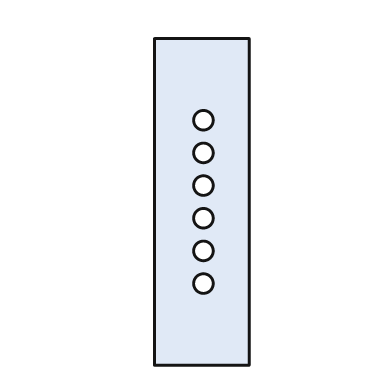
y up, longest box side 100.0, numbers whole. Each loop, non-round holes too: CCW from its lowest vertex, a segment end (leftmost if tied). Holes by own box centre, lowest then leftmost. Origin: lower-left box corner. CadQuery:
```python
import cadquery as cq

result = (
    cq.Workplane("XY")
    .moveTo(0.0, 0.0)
    .lineTo(29.0, 0.0)
    .lineTo(29.0, 100.0)
    .lineTo(0.0, 100.0)
    .close()
    .moveTo(15.0, 25.0)
    .circle(3.0)
    .moveTo(15.0, 35.0)
    .circle(3.0)
    .moveTo(15.0, 45.0)
    .circle(3.0)
    .moveTo(15.0, 55.0)
    .circle(3.0)
    .moveTo(15.0, 65.0)
    .circle(3.0)
    .moveTo(15.0, 75.0)
    .circle(3.0)
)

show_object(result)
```